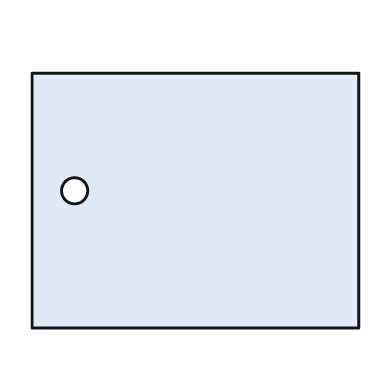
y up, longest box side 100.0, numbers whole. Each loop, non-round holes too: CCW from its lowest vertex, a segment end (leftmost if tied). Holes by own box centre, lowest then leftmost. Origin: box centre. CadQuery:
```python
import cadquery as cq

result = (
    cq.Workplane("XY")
    .moveTo(-50.0, -39.0)
    .lineTo(50.0, -39.0)
    .lineTo(50.0, 39.0)
    .lineTo(-50.0, 39.0)
    .close()
    .moveTo(-37.0, 3.0)
    .circle(4.0)
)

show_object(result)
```